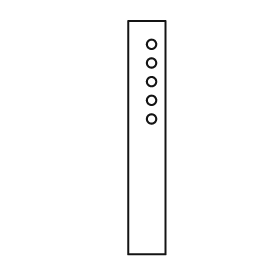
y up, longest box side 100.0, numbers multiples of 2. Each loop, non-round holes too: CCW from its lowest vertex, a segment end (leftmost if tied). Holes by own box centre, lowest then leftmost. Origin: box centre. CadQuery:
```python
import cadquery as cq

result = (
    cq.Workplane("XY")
    .moveTo(-8.0, -50.0)
    .lineTo(8.0, -50.0)
    .lineTo(8.0, 50.0)
    .lineTo(-8.0, 50.0)
    .close()
    .moveTo(2.0, 8.0)
    .circle(2.0)
    .moveTo(2.0, 16.0)
    .circle(2.0)
    .moveTo(2.0, 24.0)
    .circle(2.0)
    .moveTo(2.0, 32.0)
    .circle(2.0)
    .moveTo(2.0, 40.0)
    .circle(2.0)
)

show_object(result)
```